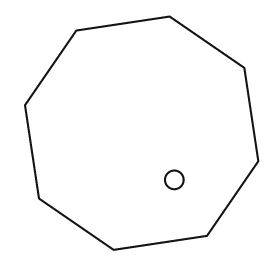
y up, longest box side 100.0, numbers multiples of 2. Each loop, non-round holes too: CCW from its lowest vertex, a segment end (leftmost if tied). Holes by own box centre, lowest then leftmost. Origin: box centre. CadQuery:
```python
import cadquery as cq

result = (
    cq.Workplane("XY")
    .moveTo(-12.0, -50.0)
    .lineTo(28.0, -44.0)
    .lineTo(50.0, -12.0)
    .lineTo(44.0, 28.0)
    .lineTo(12.0, 50.0)
    .lineTo(-28.0, 44.0)
    .lineTo(-50.0, 12.0)
    .lineTo(-44.0, -28.0)
    .close()
    .moveTo(14.0, -20.0)
    .circle(4.0)
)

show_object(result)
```